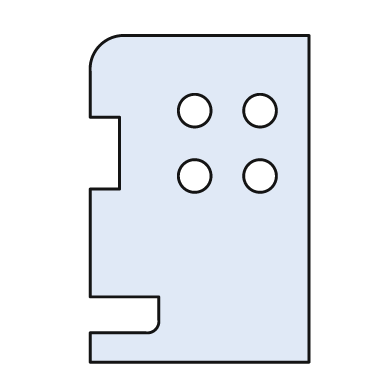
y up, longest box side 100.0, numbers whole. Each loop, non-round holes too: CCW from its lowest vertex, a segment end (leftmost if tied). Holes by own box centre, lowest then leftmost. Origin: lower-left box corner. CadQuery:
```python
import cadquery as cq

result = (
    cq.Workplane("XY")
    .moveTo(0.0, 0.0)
    .lineTo(67.0, 0.0)
    .lineTo(67.0, 100.0)
    .lineTo(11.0, 100.0)
    .threePointArc((3.0, 97.0), (0.0, 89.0))
    .lineTo(0.0, 75.0)
    .lineTo(9.0, 75.0)
    .lineTo(9.0, 53.0)
    .lineTo(0.0, 53.0)
    .lineTo(0.0, 20.0)
    .lineTo(21.0, 20.0)
    .lineTo(21.0, 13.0)
    .threePointArc((20.0, 10.0), (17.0, 9.0))
    .lineTo(0.0, 9.0)
    .close()
    .moveTo(32.0, 57.0)
    .circle(5.0)
    .moveTo(52.0, 57.0)
    .circle(5.0)
    .moveTo(32.0, 77.0)
    .circle(5.0)
    .moveTo(52.0, 77.0)
    .circle(5.0)
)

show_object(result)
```